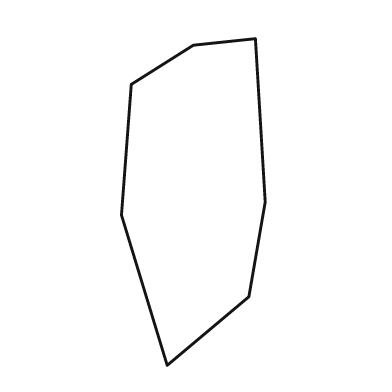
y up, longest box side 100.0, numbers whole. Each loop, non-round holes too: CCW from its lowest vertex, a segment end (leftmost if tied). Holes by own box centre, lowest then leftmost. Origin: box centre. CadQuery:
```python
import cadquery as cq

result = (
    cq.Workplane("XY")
    .moveTo(-8.0, -50.0)
    .lineTo(17.0, -29.0)
    .lineTo(22.0, 0.0)
    .lineTo(19.0, 50.0)
    .lineTo(0.0, 48.0)
    .lineTo(-19.0, 36.0)
    .lineTo(-22.0, -4.0)
    .close()
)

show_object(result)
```